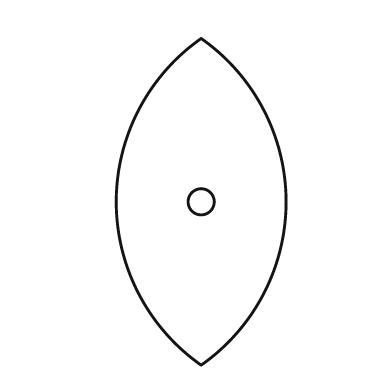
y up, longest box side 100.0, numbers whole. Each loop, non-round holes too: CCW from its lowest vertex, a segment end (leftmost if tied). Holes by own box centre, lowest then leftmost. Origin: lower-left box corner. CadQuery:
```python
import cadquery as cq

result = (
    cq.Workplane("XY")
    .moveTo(26.0, 0.0)
    .threePointArc((52.0, 50.0), (26.0, 100.0))
    .threePointArc((0.0, 50.0), (26.0, 0.0))
    .close()
    .moveTo(26.0, 50.0)
    .circle(4.0)
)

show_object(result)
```